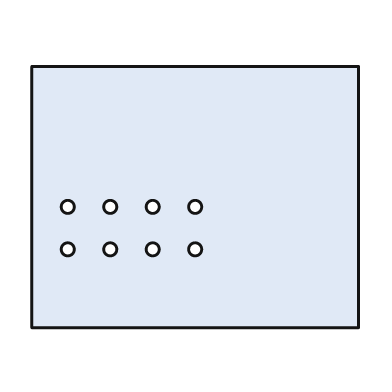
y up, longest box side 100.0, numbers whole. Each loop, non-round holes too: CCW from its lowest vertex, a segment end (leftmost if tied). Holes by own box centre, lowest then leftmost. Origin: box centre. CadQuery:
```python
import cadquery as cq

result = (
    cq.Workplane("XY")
    .moveTo(-50.0, -40.0)
    .lineTo(50.0, -40.0)
    .lineTo(50.0, 40.0)
    .lineTo(-50.0, 40.0)
    .close()
    .moveTo(-39.0, -16.0)
    .circle(2.0)
    .moveTo(-26.0, -16.0)
    .circle(2.0)
    .moveTo(-13.0, -16.0)
    .circle(2.0)
    .moveTo(0.0, -16.0)
    .circle(2.0)
    .moveTo(-39.0, -3.0)
    .circle(2.0)
    .moveTo(-26.0, -3.0)
    .circle(2.0)
    .moveTo(-13.0, -3.0)
    .circle(2.0)
    .moveTo(0.0, -3.0)
    .circle(2.0)
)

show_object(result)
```